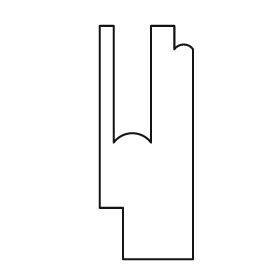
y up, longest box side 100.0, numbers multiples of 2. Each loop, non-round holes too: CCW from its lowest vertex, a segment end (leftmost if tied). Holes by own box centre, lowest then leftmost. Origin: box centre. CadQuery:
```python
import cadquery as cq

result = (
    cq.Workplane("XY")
    .moveTo(-10.0, -50.0)
    .lineTo(20.0, -50.0)
    .lineTo(20.0, 40.0)
    .threePointArc((16.0, 42.0), (12.0, 40.0))
    .lineTo(12.0, 50.0)
    .lineTo(2.0, 50.0)
    .lineTo(2.0, 0.0)
    .threePointArc((-6.0, 4.0), (-14.0, 0.0))
    .lineTo(-14.0, 50.0)
    .lineTo(-20.0, 50.0)
    .lineTo(-20.0, -28.0)
    .lineTo(-10.0, -28.0)
    .close()
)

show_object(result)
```